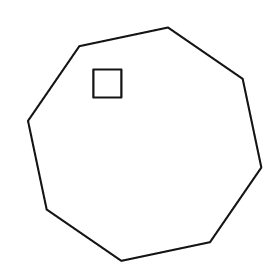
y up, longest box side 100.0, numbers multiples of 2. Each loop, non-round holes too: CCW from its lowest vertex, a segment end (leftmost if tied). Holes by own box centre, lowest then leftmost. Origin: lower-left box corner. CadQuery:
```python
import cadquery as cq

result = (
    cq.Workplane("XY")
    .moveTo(40.0, 0.0)
    .lineTo(78.0, 8.0)
    .lineTo(100.0, 40.0)
    .lineTo(92.0, 78.0)
    .lineTo(60.0, 100.0)
    .lineTo(22.0, 92.0)
    .lineTo(0.0, 60.0)
    .lineTo(8.0, 22.0)
    .close()
    .moveTo(28.0, 70.0)
    .lineTo(40.0, 70.0)
    .lineTo(40.0, 82.0)
    .lineTo(28.0, 82.0)
    .close()
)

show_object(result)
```